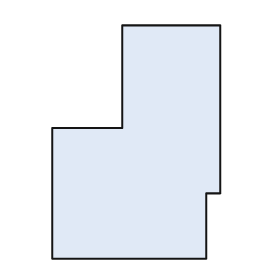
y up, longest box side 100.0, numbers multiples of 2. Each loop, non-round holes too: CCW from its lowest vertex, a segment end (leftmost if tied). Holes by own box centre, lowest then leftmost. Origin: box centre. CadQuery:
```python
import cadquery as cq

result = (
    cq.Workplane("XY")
    .moveTo(-36.0, -50.0)
    .lineTo(30.0, -50.0)
    .lineTo(30.0, -22.0)
    .lineTo(36.0, -22.0)
    .lineTo(36.0, 50.0)
    .lineTo(-6.0, 50.0)
    .lineTo(-6.0, 6.0)
    .lineTo(-36.0, 6.0)
    .close()
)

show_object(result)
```